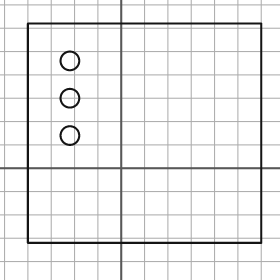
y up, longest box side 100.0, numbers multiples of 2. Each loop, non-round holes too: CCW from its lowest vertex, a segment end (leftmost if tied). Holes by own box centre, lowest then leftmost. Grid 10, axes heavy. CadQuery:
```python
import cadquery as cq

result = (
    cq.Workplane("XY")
    .moveTo(-40.0, -32.0)
    .lineTo(60.0, -32.0)
    .lineTo(60.0, 62.0)
    .lineTo(-40.0, 62.0)
    .close()
    .moveTo(-22.0, 14.0)
    .circle(4.0)
    .moveTo(-22.0, 30.0)
    .circle(4.0)
    .moveTo(-22.0, 46.0)
    .circle(4.0)
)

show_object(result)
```